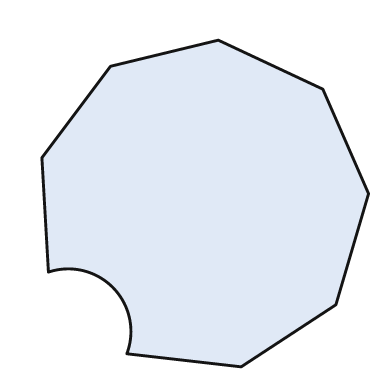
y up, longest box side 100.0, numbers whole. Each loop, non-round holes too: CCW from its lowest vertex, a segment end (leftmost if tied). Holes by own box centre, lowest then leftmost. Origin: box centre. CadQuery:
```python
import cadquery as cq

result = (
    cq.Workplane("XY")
    .moveTo(11.0, -50.0)
    .lineTo(40.0, -31.0)
    .lineTo(50.0, 3.0)
    .lineTo(36.0, 35.0)
    .lineTo(4.0, 50.0)
    .lineTo(-29.0, 42.0)
    .lineTo(-50.0, 14.0)
    .lineTo(-48.0, -21.0)
    .threePointArc((-28.0, -26.0), (-24.0, -46.0))
    .close()
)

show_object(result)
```